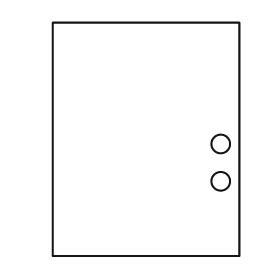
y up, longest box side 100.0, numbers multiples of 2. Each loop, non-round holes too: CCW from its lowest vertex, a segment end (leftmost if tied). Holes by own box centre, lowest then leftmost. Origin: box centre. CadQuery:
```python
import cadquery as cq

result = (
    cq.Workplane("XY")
    .moveTo(-40.0, -50.0)
    .lineTo(40.0, -50.0)
    .lineTo(40.0, 50.0)
    .lineTo(-40.0, 50.0)
    .close()
    .moveTo(32.0, -18.0)
    .circle(4.0)
    .moveTo(32.0, -2.0)
    .circle(4.0)
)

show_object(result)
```